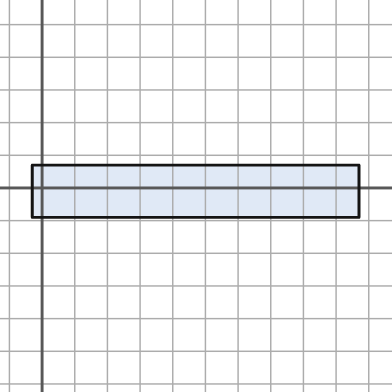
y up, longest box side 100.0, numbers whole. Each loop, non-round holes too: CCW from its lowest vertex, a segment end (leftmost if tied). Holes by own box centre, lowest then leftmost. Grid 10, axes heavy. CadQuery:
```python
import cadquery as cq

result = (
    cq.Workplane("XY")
    .moveTo(-3.0, -9.0)
    .lineTo(97.0, -9.0)
    .lineTo(97.0, 7.0)
    .lineTo(-3.0, 7.0)
    .close()
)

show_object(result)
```